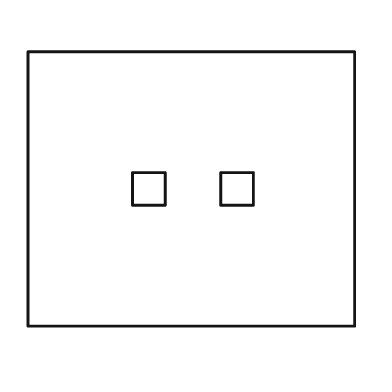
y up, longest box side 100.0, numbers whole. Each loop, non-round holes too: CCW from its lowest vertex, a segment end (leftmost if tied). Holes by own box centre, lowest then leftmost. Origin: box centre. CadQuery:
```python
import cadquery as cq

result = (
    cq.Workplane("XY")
    .moveTo(-50.0, -42.0)
    .lineTo(50.0, -42.0)
    .lineTo(50.0, 42.0)
    .lineTo(-50.0, 42.0)
    .close()
    .moveTo(-18.0, -5.0)
    .lineTo(-8.0, -5.0)
    .lineTo(-8.0, 5.0)
    .lineTo(-18.0, 5.0)
    .close()
    .moveTo(9.0, -5.0)
    .lineTo(19.0, -5.0)
    .lineTo(19.0, 5.0)
    .lineTo(9.0, 5.0)
    .close()
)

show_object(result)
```